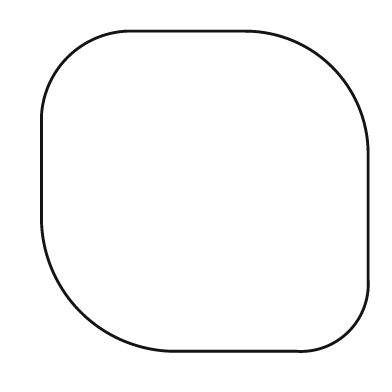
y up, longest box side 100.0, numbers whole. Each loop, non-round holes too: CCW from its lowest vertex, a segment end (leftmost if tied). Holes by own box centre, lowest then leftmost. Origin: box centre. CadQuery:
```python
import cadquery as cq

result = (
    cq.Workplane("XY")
    .moveTo(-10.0, -49.0)
    .lineTo(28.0, -49.0)
    .threePointArc((44.0, -43.0), (50.0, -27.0))
    .lineTo(50.0, 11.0)
    .threePointArc((39.0, 38.0), (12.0, 49.0))
    .lineTo(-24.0, 49.0)
    .threePointArc((-42.0, 41.0), (-50.0, 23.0))
    .lineTo(-50.0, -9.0)
    .threePointArc((-38.0, -37.0), (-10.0, -49.0))
    .close()
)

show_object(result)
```